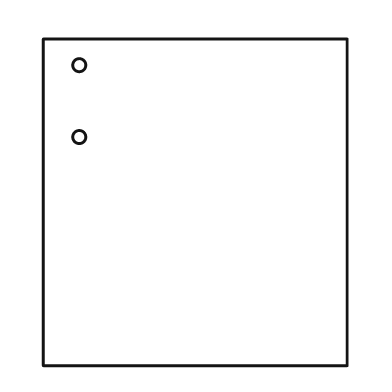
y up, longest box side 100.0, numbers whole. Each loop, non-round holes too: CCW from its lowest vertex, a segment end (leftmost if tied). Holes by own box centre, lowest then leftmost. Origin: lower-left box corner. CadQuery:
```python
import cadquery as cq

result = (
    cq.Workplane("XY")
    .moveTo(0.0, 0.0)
    .lineTo(93.0, 0.0)
    .lineTo(93.0, 100.0)
    .lineTo(0.0, 100.0)
    .close()
    .moveTo(11.0, 70.0)
    .circle(2.0)
    .moveTo(11.0, 92.0)
    .circle(2.0)
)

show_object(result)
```